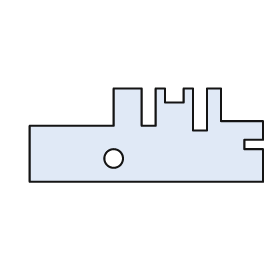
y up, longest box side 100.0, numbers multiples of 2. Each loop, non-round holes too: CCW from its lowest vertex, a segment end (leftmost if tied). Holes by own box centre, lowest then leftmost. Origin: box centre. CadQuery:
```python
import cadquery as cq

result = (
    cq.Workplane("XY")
    .moveTo(-50.0, -20.0)
    .lineTo(50.0, -20.0)
    .lineTo(50.0, -6.0)
    .lineTo(42.0, -6.0)
    .lineTo(42.0, -2.0)
    .lineTo(50.0, -2.0)
    .lineTo(50.0, 6.0)
    .lineTo(32.0, 6.0)
    .lineTo(32.0, 20.0)
    .lineTo(26.0, 20.0)
    .lineTo(26.0, 2.0)
    .lineTo(20.0, 2.0)
    .lineTo(20.0, 20.0)
    .lineTo(16.0, 20.0)
    .lineTo(16.0, 14.0)
    .lineTo(8.0, 14.0)
    .lineTo(8.0, 20.0)
    .lineTo(4.0, 20.0)
    .lineTo(4.0, 4.0)
    .lineTo(-2.0, 4.0)
    .lineTo(-2.0, 20.0)
    .lineTo(-14.0, 20.0)
    .lineTo(-14.0, 4.0)
    .lineTo(-50.0, 4.0)
    .close()
    .moveTo(-14.0, -10.0)
    .circle(4.0)
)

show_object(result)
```